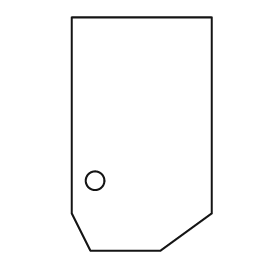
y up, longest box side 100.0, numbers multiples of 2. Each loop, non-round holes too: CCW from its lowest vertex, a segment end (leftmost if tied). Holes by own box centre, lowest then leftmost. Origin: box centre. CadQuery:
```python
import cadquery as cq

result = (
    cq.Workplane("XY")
    .moveTo(-22.0, -50.0)
    .lineTo(8.0, -50.0)
    .lineTo(30.0, -34.0)
    .lineTo(30.0, 50.0)
    .lineTo(-30.0, 50.0)
    .lineTo(-30.0, -34.0)
    .close()
    .moveTo(-20.0, -20.0)
    .circle(4.0)
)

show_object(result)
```